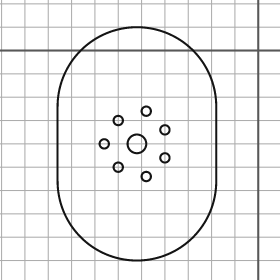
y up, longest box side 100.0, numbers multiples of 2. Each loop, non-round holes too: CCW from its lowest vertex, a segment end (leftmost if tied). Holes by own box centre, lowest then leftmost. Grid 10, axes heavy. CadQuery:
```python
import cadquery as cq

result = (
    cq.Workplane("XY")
    .moveTo(-86.0, -56.0)
    .threePointArc((-52.0, -90.0), (-18.0, -56.0))
    .lineTo(-18.0, -24.0)
    .threePointArc((-52.0, 10.0), (-86.0, -24.0))
    .close()
    .moveTo(-48.0, -54.0)
    .circle(2.0)
    .moveTo(-60.0, -50.0)
    .circle(2.0)
    .moveTo(-40.0, -46.0)
    .circle(2.0)
    .moveTo(-66.0, -40.0)
    .circle(2.0)
    .moveTo(-52.0, -40.0)
    .circle(4.0)
    .moveTo(-40.0, -34.0)
    .circle(2.0)
    .moveTo(-60.0, -30.0)
    .circle(2.0)
    .moveTo(-48.0, -26.0)
    .circle(2.0)
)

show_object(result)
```